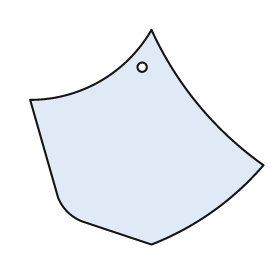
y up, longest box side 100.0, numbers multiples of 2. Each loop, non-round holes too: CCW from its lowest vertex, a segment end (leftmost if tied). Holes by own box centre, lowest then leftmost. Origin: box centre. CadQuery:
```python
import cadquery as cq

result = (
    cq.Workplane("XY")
    .moveTo(2.0, -46.0)
    .threePointArc((28.0, -32.0), (50.0, -12.0))
    .threePointArc((22.0, 14.0), (2.0, 46.0))
    .threePointArc((-20.0, 24.0), (-50.0, 16.0))
    .lineTo(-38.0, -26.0)
    .threePointArc((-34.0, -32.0), (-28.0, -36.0))
    .close()
    .moveTo(-2.0, 30.0)
    .circle(2.0)
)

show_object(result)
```